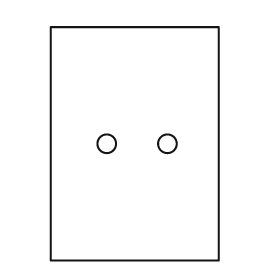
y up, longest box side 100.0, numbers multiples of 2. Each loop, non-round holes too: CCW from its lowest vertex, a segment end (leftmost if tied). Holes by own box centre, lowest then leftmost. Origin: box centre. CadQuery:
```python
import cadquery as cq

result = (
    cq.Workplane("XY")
    .moveTo(-36.0, -50.0)
    .lineTo(36.0, -50.0)
    .lineTo(36.0, 50.0)
    .lineTo(-36.0, 50.0)
    .close()
    .moveTo(-12.0, 0.0)
    .circle(4.0)
    .moveTo(14.0, 0.0)
    .circle(4.0)
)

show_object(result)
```